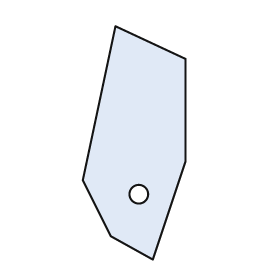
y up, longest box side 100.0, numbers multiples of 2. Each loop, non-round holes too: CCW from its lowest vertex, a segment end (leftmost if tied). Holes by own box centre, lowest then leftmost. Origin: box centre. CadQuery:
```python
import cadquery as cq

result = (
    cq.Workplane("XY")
    .moveTo(8.0, -50.0)
    .lineTo(22.0, -8.0)
    .lineTo(22.0, 36.0)
    .lineTo(-8.0, 50.0)
    .lineTo(-22.0, -16.0)
    .lineTo(-10.0, -40.0)
    .close()
    .moveTo(2.0, -22.0)
    .circle(4.0)
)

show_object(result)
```